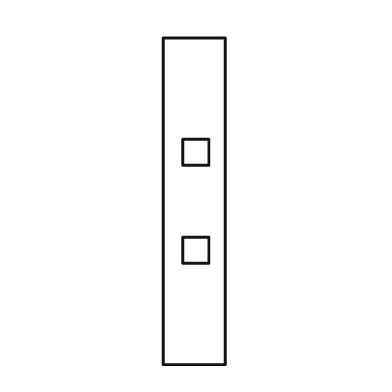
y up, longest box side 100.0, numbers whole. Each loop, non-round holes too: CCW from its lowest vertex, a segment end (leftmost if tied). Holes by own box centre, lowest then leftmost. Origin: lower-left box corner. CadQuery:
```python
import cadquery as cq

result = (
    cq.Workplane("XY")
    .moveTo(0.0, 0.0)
    .lineTo(19.0, 0.0)
    .lineTo(19.0, 100.0)
    .lineTo(0.0, 100.0)
    .close()
    .moveTo(6.0, 31.0)
    .lineTo(14.0, 31.0)
    .lineTo(14.0, 39.0)
    .lineTo(6.0, 39.0)
    .close()
    .moveTo(6.0, 61.0)
    .lineTo(14.0, 61.0)
    .lineTo(14.0, 69.0)
    .lineTo(6.0, 69.0)
    .close()
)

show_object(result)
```